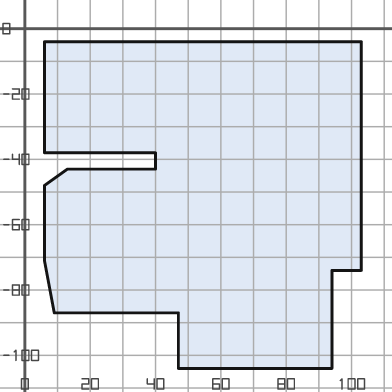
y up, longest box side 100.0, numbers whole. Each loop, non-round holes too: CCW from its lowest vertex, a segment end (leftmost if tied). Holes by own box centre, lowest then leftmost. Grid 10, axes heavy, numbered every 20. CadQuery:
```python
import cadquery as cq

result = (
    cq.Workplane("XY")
    .moveTo(47.0, -104.0)
    .lineTo(94.0, -104.0)
    .lineTo(94.0, -74.0)
    .lineTo(103.0, -74.0)
    .lineTo(103.0, -4.0)
    .lineTo(6.0, -4.0)
    .lineTo(6.0, -38.0)
    .lineTo(40.0, -38.0)
    .lineTo(40.0, -43.0)
    .lineTo(13.0, -43.0)
    .lineTo(6.0, -48.0)
    .lineTo(6.0, -71.0)
    .lineTo(9.0, -87.0)
    .lineTo(47.0, -87.0)
    .close()
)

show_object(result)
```